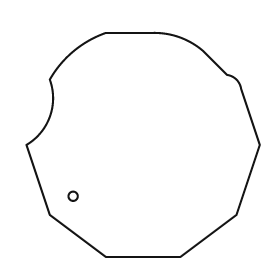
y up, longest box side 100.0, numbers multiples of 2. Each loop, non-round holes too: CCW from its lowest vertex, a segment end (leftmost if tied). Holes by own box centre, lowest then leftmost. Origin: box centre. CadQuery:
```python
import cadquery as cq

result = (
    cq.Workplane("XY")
    .moveTo(-16.0, -48.0)
    .lineTo(16.0, -48.0)
    .lineTo(40.0, -30.0)
    .lineTo(50.0, 0.0)
    .lineTo(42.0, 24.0)
    .threePointArc((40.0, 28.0), (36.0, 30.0))
    .lineTo(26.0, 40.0)
    .threePointArc((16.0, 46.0), (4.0, 48.0))
    .lineTo(-16.0, 48.0)
    .threePointArc((-30.0, 40.0), (-40.0, 28.0))
    .threePointArc((-40.0, 12.0), (-50.0, 0.0))
    .lineTo(-40.0, -30.0)
    .close()
    .moveTo(-30.0, -22.0)
    .circle(2.0)
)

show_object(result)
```